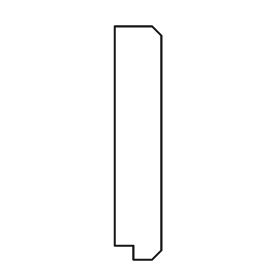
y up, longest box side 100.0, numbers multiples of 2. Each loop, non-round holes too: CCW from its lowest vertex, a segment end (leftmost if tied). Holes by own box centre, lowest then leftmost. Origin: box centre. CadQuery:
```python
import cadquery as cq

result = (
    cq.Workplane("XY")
    .moveTo(-2.0, -50.0)
    .lineTo(6.0, -50.0)
    .lineTo(10.0, -46.0)
    .lineTo(10.0, 46.0)
    .lineTo(6.0, 50.0)
    .lineTo(-10.0, 50.0)
    .lineTo(-10.0, -44.0)
    .lineTo(-2.0, -44.0)
    .close()
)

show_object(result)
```